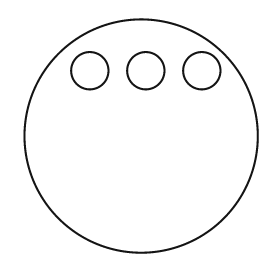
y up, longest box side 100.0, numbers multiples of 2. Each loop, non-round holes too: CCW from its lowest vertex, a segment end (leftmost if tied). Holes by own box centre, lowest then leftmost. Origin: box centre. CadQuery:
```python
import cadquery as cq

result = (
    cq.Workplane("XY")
    .moveTo(0.0, 0.0)
    .circle(50.0)
    .moveTo(-22.0, 28.0)
    .circle(8.0)
    .moveTo(2.0, 28.0)
    .circle(8.0)
    .moveTo(26.0, 28.0)
    .circle(8.0)
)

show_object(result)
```